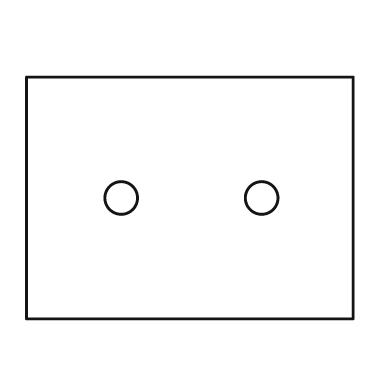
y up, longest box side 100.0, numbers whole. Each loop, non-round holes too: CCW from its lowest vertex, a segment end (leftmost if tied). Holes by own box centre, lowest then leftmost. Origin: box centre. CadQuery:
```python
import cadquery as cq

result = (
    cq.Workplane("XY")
    .moveTo(-50.0, -37.0)
    .lineTo(50.0, -37.0)
    .lineTo(50.0, 37.0)
    .lineTo(-50.0, 37.0)
    .close()
    .moveTo(-21.0, 0.0)
    .circle(5.0)
    .moveTo(22.0, 0.0)
    .circle(5.0)
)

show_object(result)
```